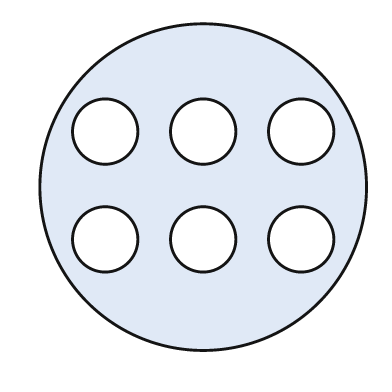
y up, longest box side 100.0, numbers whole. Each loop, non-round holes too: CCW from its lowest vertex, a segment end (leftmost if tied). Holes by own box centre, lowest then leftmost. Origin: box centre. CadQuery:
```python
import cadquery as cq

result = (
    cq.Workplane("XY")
    .moveTo(0.0, 0.0)
    .circle(50.0)
    .moveTo(-30.0, -16.0)
    .circle(10.0)
    .moveTo(0.0, -16.0)
    .circle(10.0)
    .moveTo(30.0, -16.0)
    .circle(10.0)
    .moveTo(-30.0, 17.0)
    .circle(10.0)
    .moveTo(0.0, 17.0)
    .circle(10.0)
    .moveTo(30.0, 17.0)
    .circle(10.0)
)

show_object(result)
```